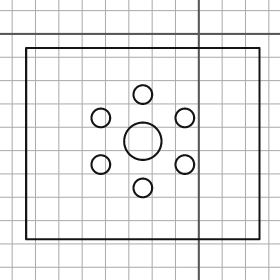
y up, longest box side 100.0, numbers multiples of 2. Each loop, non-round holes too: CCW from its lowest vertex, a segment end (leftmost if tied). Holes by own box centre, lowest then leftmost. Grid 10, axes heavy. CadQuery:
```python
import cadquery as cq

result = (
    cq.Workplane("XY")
    .moveTo(-74.0, -88.0)
    .lineTo(26.0, -88.0)
    .lineTo(26.0, -6.0)
    .lineTo(-74.0, -6.0)
    .close()
    .moveTo(-24.0, -66.0)
    .circle(4.0)
    .moveTo(-42.0, -56.0)
    .circle(4.0)
    .moveTo(-6.0, -56.0)
    .circle(4.0)
    .moveTo(-24.0, -46.0)
    .circle(8.0)
    .moveTo(-42.0, -36.0)
    .circle(4.0)
    .moveTo(-6.0, -36.0)
    .circle(4.0)
    .moveTo(-24.0, -26.0)
    .circle(4.0)
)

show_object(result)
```